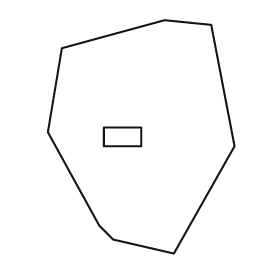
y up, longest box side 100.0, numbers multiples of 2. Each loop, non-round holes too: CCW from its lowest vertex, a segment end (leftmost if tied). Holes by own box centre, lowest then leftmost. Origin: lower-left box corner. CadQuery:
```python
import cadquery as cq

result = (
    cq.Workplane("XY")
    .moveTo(54.0, 0.0)
    .lineTo(80.0, 46.0)
    .lineTo(70.0, 98.0)
    .lineTo(50.0, 100.0)
    .lineTo(6.0, 88.0)
    .lineTo(0.0, 52.0)
    .lineTo(22.0, 12.0)
    .lineTo(28.0, 6.0)
    .close()
    .moveTo(24.0, 46.0)
    .lineTo(40.0, 46.0)
    .lineTo(40.0, 54.0)
    .lineTo(24.0, 54.0)
    .close()
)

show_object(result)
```